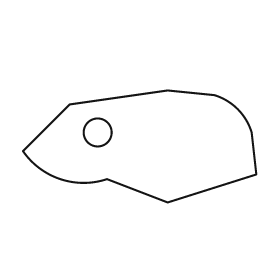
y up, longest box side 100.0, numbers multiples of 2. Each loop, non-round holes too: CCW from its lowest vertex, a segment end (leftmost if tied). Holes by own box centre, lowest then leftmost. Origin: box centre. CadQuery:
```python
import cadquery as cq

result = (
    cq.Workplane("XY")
    .moveTo(12.0, -24.0)
    .lineTo(50.0, -12.0)
    .lineTo(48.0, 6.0)
    .threePointArc((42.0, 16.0), (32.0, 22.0))
    .lineTo(12.0, 24.0)
    .lineTo(-30.0, 18.0)
    .lineTo(-50.0, -2.0)
    .threePointArc((-34.0, -14.0), (-14.0, -14.0))
    .close()
    .moveTo(-18.0, 6.0)
    .circle(6.0)
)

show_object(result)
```